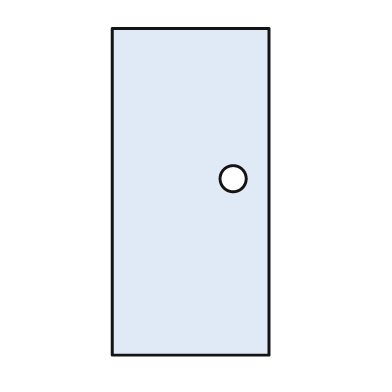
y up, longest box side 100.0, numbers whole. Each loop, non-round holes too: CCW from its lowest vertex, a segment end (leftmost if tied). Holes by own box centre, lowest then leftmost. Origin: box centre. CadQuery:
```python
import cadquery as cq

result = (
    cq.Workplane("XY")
    .moveTo(-24.0, -50.0)
    .lineTo(24.0, -50.0)
    .lineTo(24.0, 50.0)
    .lineTo(-24.0, 50.0)
    .close()
    .moveTo(13.0, 4.0)
    .circle(4.0)
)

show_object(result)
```